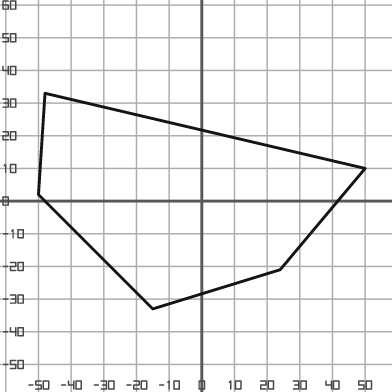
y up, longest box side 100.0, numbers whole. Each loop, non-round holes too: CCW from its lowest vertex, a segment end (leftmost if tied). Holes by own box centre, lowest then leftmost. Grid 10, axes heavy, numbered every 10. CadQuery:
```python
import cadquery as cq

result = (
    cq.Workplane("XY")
    .moveTo(-15.0, -33.0)
    .lineTo(24.0, -21.0)
    .lineTo(50.0, 10.0)
    .lineTo(-48.0, 33.0)
    .lineTo(-50.0, 2.0)
    .close()
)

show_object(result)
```